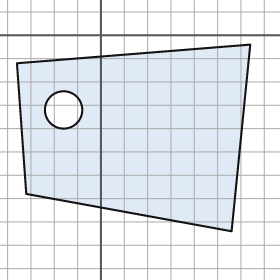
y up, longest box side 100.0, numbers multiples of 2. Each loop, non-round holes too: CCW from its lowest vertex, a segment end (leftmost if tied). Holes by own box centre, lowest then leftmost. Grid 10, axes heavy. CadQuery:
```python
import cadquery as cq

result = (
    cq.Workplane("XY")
    .moveTo(56.0, -84.0)
    .lineTo(64.0, -4.0)
    .lineTo(-36.0, -12.0)
    .lineTo(-32.0, -68.0)
    .close()
    .moveTo(-16.0, -32.0)
    .circle(8.0)
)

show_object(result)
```